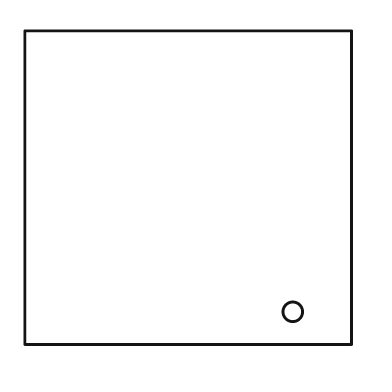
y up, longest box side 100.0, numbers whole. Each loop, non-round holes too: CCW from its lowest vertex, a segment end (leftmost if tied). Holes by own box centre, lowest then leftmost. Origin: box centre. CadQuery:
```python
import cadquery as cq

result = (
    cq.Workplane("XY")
    .moveTo(-50.0, -48.0)
    .lineTo(50.0, -48.0)
    .lineTo(50.0, 48.0)
    .lineTo(-50.0, 48.0)
    .close()
    .moveTo(32.0, -38.0)
    .circle(3.0)
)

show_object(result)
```